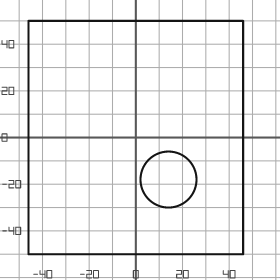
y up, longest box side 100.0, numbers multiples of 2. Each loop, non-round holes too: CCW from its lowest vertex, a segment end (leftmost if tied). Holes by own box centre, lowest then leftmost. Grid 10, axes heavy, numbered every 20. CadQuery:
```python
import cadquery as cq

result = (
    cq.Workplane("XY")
    .moveTo(-46.0, -50.0)
    .lineTo(46.0, -50.0)
    .lineTo(46.0, 50.0)
    .lineTo(-46.0, 50.0)
    .close()
    .moveTo(14.0, -18.0)
    .circle(12.0)
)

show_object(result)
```